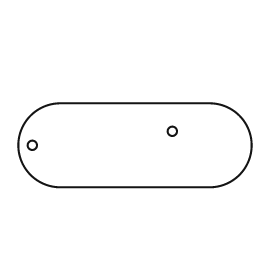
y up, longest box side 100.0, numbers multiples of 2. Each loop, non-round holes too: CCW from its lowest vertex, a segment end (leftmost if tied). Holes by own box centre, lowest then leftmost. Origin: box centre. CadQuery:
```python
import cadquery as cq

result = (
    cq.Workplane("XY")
    .moveTo(-32.0, -18.0)
    .lineTo(32.0, -18.0)
    .threePointArc((50.0, 0.0), (32.0, 18.0))
    .lineTo(-32.0, 18.0)
    .threePointArc((-50.0, 0.0), (-32.0, -18.0))
    .close()
    .moveTo(-44.0, 0.0)
    .circle(2.0)
    .moveTo(16.0, 6.0)
    .circle(2.0)
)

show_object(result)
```